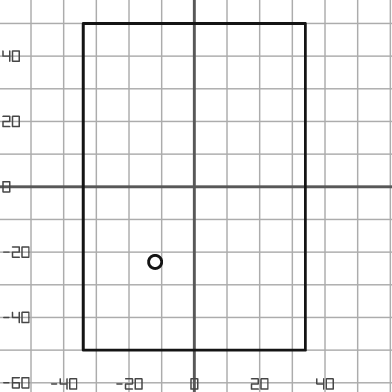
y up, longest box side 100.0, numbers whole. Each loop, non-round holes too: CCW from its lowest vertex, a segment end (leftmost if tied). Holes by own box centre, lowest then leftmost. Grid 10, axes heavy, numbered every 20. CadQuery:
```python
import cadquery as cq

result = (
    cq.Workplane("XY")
    .moveTo(-34.0, -50.0)
    .lineTo(34.0, -50.0)
    .lineTo(34.0, 50.0)
    .lineTo(-34.0, 50.0)
    .close()
    .moveTo(-12.0, -23.0)
    .circle(2.0)
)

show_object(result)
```